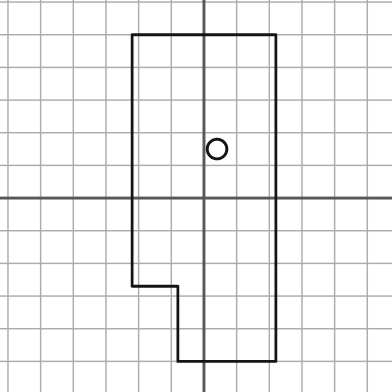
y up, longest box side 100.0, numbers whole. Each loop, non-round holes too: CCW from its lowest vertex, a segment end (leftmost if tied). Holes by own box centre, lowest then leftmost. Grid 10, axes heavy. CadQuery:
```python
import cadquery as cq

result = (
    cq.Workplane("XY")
    .moveTo(-8.0, -50.0)
    .lineTo(22.0, -50.0)
    .lineTo(22.0, 50.0)
    .lineTo(-22.0, 50.0)
    .lineTo(-22.0, -27.0)
    .lineTo(-8.0, -27.0)
    .close()
    .moveTo(4.0, 15.0)
    .circle(3.0)
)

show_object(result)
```